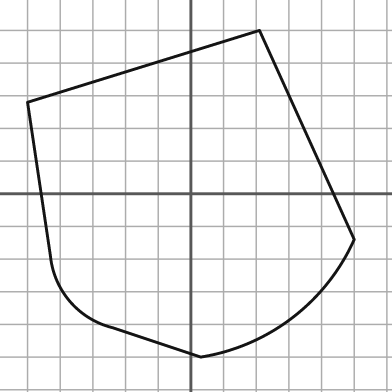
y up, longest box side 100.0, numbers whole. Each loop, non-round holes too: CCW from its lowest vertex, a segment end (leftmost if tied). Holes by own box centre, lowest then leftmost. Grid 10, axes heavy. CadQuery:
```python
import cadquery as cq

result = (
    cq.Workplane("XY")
    .moveTo(3.0, -50.0)
    .threePointArc((31.0, -38.0), (50.0, -14.0))
    .lineTo(21.0, 50.0)
    .lineTo(-50.0, 28.0)
    .lineTo(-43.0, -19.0)
    .threePointArc((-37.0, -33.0), (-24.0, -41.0))
    .close()
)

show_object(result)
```